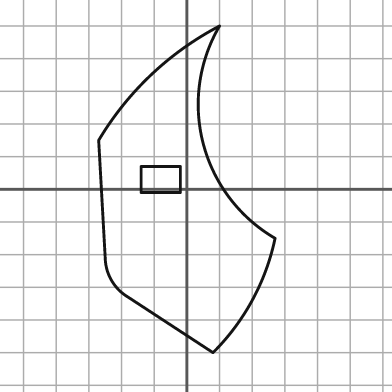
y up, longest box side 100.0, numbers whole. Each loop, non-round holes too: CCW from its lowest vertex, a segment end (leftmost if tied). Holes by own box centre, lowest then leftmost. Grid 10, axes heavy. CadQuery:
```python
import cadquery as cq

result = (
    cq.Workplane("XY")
    .moveTo(8.0, -50.0)
    .threePointArc((20.0, -34.0), (27.0, -15.0))
    .threePointArc((5.0, 14.0), (10.0, 50.0))
    .threePointArc((-11.0, 35.0), (-27.0, 15.0))
    .lineTo(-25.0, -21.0)
    .threePointArc((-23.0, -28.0), (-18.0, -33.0))
    .close()
    .moveTo(-14.0, -1.0)
    .lineTo(-2.0, -1.0)
    .lineTo(-2.0, 7.0)
    .lineTo(-14.0, 7.0)
    .close()
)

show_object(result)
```